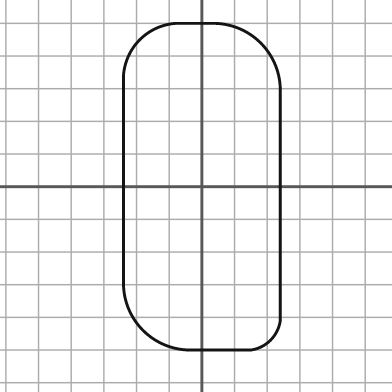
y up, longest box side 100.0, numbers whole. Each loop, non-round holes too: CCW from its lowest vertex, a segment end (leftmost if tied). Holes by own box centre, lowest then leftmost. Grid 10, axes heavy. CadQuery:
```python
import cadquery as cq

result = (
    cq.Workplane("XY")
    .moveTo(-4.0, -50.0)
    .lineTo(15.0, -50.0)
    .threePointArc((21.0, -47.0), (24.0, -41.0))
    .lineTo(24.0, 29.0)
    .threePointArc((18.0, 44.0), (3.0, 50.0))
    .lineTo(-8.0, 50.0)
    .threePointArc((-19.0, 45.0), (-24.0, 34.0))
    .lineTo(-24.0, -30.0)
    .threePointArc((-18.0, -44.0), (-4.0, -50.0))
    .close()
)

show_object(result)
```